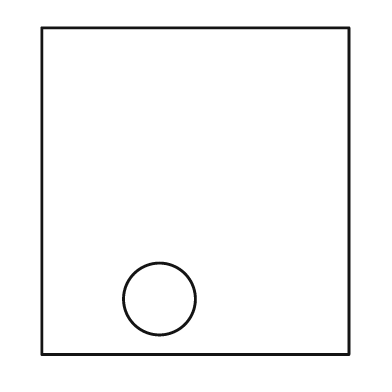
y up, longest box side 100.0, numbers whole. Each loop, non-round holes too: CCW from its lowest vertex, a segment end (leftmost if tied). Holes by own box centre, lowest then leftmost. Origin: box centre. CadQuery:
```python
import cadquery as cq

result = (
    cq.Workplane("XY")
    .moveTo(-47.0, -50.0)
    .lineTo(47.0, -50.0)
    .lineTo(47.0, 50.0)
    .lineTo(-47.0, 50.0)
    .close()
    .moveTo(-11.0, -33.0)
    .circle(11.0)
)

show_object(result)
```